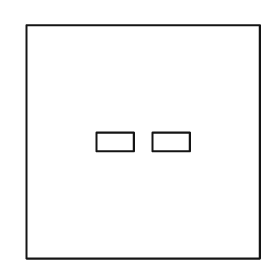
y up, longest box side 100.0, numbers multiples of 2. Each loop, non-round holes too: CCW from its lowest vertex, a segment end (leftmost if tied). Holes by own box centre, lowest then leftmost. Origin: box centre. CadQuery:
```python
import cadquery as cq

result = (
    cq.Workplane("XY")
    .moveTo(-50.0, -50.0)
    .lineTo(50.0, -50.0)
    .lineTo(50.0, 50.0)
    .lineTo(-50.0, 50.0)
    .close()
    .moveTo(-20.0, -4.0)
    .lineTo(-4.0, -4.0)
    .lineTo(-4.0, 4.0)
    .lineTo(-20.0, 4.0)
    .close()
    .moveTo(4.0, -4.0)
    .lineTo(20.0, -4.0)
    .lineTo(20.0, 4.0)
    .lineTo(4.0, 4.0)
    .close()
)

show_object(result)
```